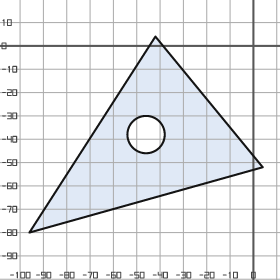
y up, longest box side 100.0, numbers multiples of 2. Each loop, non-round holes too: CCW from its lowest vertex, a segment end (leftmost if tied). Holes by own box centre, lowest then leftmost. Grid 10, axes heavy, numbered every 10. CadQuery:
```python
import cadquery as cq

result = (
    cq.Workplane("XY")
    .moveTo(-96.0, -80.0)
    .lineTo(4.0, -52.0)
    .lineTo(-42.0, 4.0)
    .close()
    .moveTo(-46.0, -38.0)
    .circle(8.0)
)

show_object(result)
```